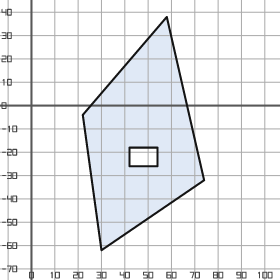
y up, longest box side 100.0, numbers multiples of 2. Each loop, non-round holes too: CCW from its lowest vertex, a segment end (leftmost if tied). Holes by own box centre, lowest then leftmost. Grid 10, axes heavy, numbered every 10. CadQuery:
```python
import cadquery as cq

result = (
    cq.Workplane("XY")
    .moveTo(30.0, -62.0)
    .lineTo(74.0, -32.0)
    .lineTo(58.0, 38.0)
    .lineTo(22.0, -4.0)
    .close()
    .moveTo(42.0, -26.0)
    .lineTo(54.0, -26.0)
    .lineTo(54.0, -18.0)
    .lineTo(42.0, -18.0)
    .close()
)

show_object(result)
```